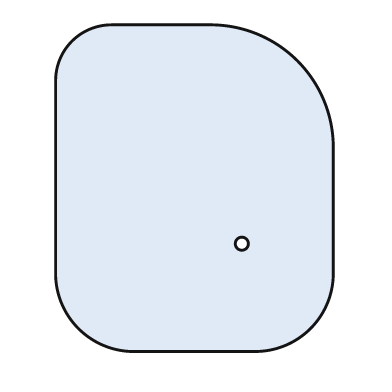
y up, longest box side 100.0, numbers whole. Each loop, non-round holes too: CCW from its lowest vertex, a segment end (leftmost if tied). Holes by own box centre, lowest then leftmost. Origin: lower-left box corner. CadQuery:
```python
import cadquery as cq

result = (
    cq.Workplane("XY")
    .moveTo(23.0, 0.0)
    .lineTo(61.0, 0.0)
    .threePointArc((78.0, 7.0), (85.0, 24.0))
    .lineTo(85.0, 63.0)
    .threePointArc((74.0, 89.0), (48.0, 100.0))
    .lineTo(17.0, 100.0)
    .threePointArc((5.0, 95.0), (0.0, 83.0))
    .lineTo(0.0, 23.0)
    .threePointArc((7.0, 7.0), (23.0, 0.0))
    .close()
    .moveTo(57.0, 33.0)
    .circle(2.0)
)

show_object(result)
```